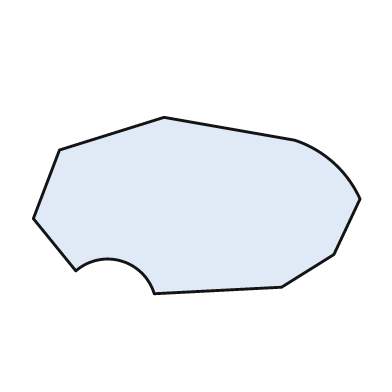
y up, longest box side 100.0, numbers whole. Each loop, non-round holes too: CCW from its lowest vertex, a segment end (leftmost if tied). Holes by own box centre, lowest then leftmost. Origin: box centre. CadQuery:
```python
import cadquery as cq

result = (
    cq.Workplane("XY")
    .moveTo(-13.0, -27.0)
    .lineTo(26.0, -25.0)
    .lineTo(42.0, -15.0)
    .lineTo(50.0, 2.0)
    .threePointArc((42.0, 13.0), (30.0, 20.0))
    .lineTo(-10.0, 27.0)
    .lineTo(-42.0, 17.0)
    .lineTo(-50.0, -4.0)
    .lineTo(-37.0, -20.0)
    .threePointArc((-23.0, -17.0), (-13.0, -27.0))
    .close()
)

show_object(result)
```